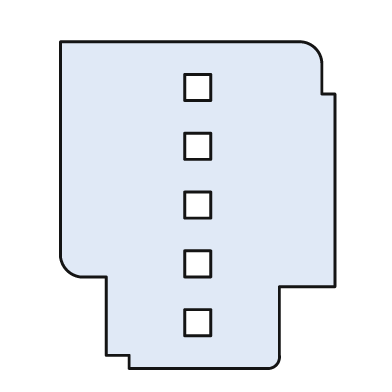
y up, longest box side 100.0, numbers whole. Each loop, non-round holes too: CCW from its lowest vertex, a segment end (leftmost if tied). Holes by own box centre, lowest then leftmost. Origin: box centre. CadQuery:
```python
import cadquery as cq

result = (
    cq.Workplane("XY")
    .moveTo(-21.0, -50.0)
    .lineTo(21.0, -50.0)
    .threePointArc((24.0, -49.0), (25.0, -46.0))
    .lineTo(25.0, -25.0)
    .lineTo(42.0, -25.0)
    .lineTo(42.0, 34.0)
    .lineTo(38.0, 34.0)
    .lineTo(38.0, 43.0)
    .threePointArc((36.0, 48.0), (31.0, 50.0))
    .lineTo(-42.0, 50.0)
    .lineTo(-42.0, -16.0)
    .threePointArc((-40.0, -20.0), (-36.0, -22.0))
    .lineTo(-28.0, -22.0)
    .lineTo(-28.0, -46.0)
    .lineTo(-21.0, -46.0)
    .close()
    .moveTo(-4.0, -40.0)
    .lineTo(4.0, -40.0)
    .lineTo(4.0, -32.0)
    .lineTo(-4.0, -32.0)
    .close()
    .moveTo(-4.0, -22.0)
    .lineTo(4.0, -22.0)
    .lineTo(4.0, -14.0)
    .lineTo(-4.0, -14.0)
    .close()
    .moveTo(-4.0, -4.0)
    .lineTo(4.0, -4.0)
    .lineTo(4.0, 4.0)
    .lineTo(-4.0, 4.0)
    .close()
    .moveTo(-4.0, 14.0)
    .lineTo(4.0, 14.0)
    .lineTo(4.0, 22.0)
    .lineTo(-4.0, 22.0)
    .close()
    .moveTo(-4.0, 32.0)
    .lineTo(4.0, 32.0)
    .lineTo(4.0, 40.0)
    .lineTo(-4.0, 40.0)
    .close()
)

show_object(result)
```